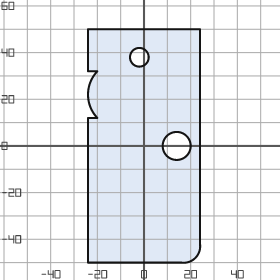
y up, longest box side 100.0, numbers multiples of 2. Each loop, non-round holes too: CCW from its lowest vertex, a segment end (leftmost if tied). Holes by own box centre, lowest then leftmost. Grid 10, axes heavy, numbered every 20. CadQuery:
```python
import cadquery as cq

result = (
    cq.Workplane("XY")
    .moveTo(-24.0, -50.0)
    .lineTo(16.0, -50.0)
    .threePointArc((22.0, -48.0), (24.0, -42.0))
    .lineTo(24.0, 50.0)
    .lineTo(-24.0, 50.0)
    .lineTo(-24.0, 32.0)
    .lineTo(-20.0, 32.0)
    .threePointArc((-24.0, 22.0), (-20.0, 12.0))
    .lineTo(-24.0, 12.0)
    .close()
    .moveTo(14.0, 0.0)
    .circle(6.0)
    .moveTo(-2.0, 38.0)
    .circle(4.0)
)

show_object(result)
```